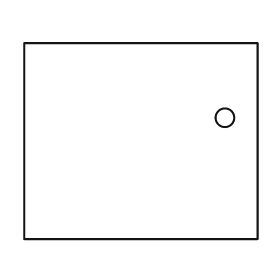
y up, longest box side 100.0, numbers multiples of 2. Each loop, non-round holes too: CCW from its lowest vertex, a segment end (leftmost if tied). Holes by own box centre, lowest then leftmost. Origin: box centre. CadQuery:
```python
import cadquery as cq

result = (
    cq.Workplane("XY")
    .moveTo(-50.0, -42.0)
    .lineTo(50.0, -42.0)
    .lineTo(50.0, 42.0)
    .lineTo(-50.0, 42.0)
    .close()
    .moveTo(36.0, 10.0)
    .circle(4.0)
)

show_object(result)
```